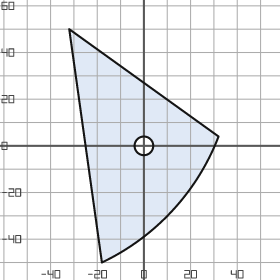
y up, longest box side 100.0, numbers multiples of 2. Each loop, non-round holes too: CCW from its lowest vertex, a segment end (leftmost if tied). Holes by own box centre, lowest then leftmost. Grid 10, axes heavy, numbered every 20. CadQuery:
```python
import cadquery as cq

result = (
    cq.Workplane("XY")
    .moveTo(-18.0, -50.0)
    .threePointArc((12.0, -28.0), (32.0, 4.0))
    .lineTo(-32.0, 50.0)
    .close()
    .moveTo(0.0, 0.0)
    .circle(4.0)
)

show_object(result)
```